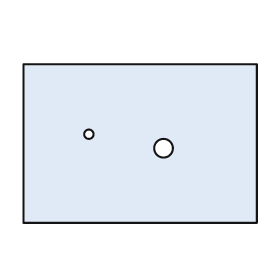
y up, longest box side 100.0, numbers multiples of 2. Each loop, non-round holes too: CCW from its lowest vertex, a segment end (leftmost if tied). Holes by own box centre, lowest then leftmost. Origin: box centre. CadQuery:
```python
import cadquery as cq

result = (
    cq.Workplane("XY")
    .moveTo(-50.0, -34.0)
    .lineTo(50.0, -34.0)
    .lineTo(50.0, 34.0)
    .lineTo(-50.0, 34.0)
    .close()
    .moveTo(10.0, -2.0)
    .circle(4.0)
    .moveTo(-22.0, 4.0)
    .circle(2.0)
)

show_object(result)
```